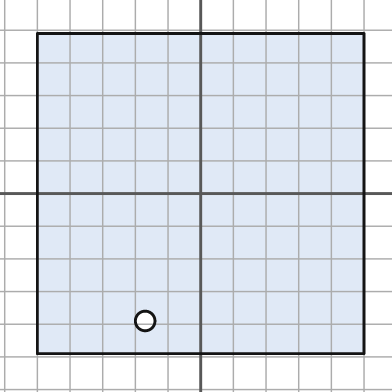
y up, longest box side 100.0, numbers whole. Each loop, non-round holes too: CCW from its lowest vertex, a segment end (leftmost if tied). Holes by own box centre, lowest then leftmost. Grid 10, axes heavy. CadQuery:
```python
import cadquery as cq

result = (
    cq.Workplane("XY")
    .moveTo(-50.0, -49.0)
    .lineTo(50.0, -49.0)
    .lineTo(50.0, 49.0)
    .lineTo(-50.0, 49.0)
    .close()
    .moveTo(-17.0, -39.0)
    .circle(3.0)
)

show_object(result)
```